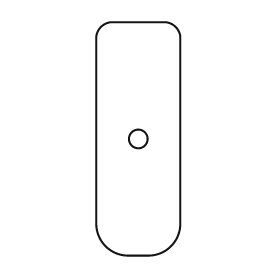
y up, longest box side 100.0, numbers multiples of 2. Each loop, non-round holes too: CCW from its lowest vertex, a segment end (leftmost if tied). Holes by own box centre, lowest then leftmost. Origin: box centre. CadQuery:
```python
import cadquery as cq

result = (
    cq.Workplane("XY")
    .moveTo(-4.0, -50.0)
    .lineTo(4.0, -50.0)
    .threePointArc((14.0, -46.0), (18.0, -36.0))
    .lineTo(18.0, 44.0)
    .threePointArc((16.0, 48.0), (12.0, 50.0))
    .lineTo(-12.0, 50.0)
    .threePointArc((-16.0, 48.0), (-18.0, 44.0))
    .lineTo(-18.0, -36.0)
    .threePointArc((-14.0, -46.0), (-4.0, -50.0))
    .close()
    .moveTo(0.0, 0.0)
    .circle(4.0)
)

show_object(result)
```